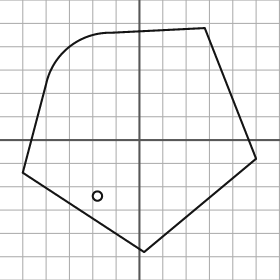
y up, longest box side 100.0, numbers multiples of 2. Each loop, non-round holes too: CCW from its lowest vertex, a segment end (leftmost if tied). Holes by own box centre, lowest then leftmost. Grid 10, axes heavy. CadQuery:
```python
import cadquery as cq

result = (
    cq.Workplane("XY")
    .moveTo(2.0, -48.0)
    .lineTo(50.0, -8.0)
    .lineTo(28.0, 48.0)
    .lineTo(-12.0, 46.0)
    .threePointArc((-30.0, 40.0), (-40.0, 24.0))
    .lineTo(-50.0, -14.0)
    .close()
    .moveTo(-18.0, -24.0)
    .circle(2.0)
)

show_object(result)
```